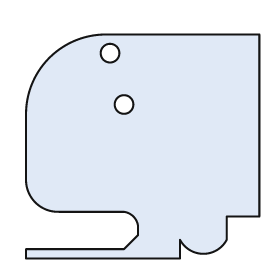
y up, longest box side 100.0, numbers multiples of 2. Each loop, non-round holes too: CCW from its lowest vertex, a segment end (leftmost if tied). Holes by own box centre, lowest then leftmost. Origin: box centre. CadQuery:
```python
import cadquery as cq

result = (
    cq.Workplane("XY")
    .moveTo(-50.0, -48.0)
    .lineTo(16.0, -48.0)
    .lineTo(16.0, -40.0)
    .threePointArc((26.0, -46.0), (36.0, -40.0))
    .lineTo(36.0, -30.0)
    .lineTo(50.0, -30.0)
    .lineTo(50.0, 48.0)
    .lineTo(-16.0, 48.0)
    .threePointArc((-40.0, 38.0), (-50.0, 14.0))
    .lineTo(-50.0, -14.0)
    .threePointArc((-46.0, -24.0), (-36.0, -28.0))
    .lineTo(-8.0, -28.0)
    .threePointArc((-4.0, -30.0), (-2.0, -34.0))
    .lineTo(-2.0, -38.0)
    .lineTo(-8.0, -44.0)
    .lineTo(-50.0, -44.0)
    .close()
    .moveTo(-8.0, 18.0)
    .circle(4.0)
    .moveTo(-14.0, 40.0)
    .circle(4.0)
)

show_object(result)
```